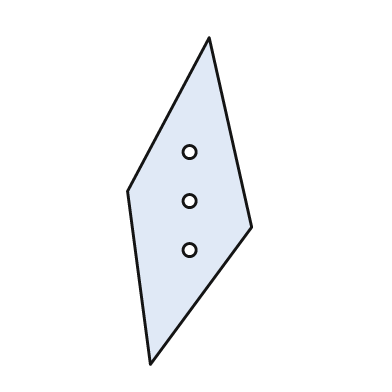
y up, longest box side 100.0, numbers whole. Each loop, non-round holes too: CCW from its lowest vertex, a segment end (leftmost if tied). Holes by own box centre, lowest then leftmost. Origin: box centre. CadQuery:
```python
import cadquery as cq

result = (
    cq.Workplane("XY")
    .moveTo(-12.0, -50.0)
    .lineTo(19.0, -8.0)
    .lineTo(6.0, 50.0)
    .lineTo(-19.0, 3.0)
    .close()
    .moveTo(0.0, -15.0)
    .circle(2.0)
    .moveTo(0.0, 0.0)
    .circle(2.0)
    .moveTo(0.0, 15.0)
    .circle(2.0)
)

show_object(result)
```